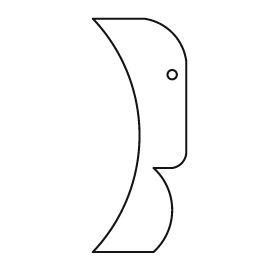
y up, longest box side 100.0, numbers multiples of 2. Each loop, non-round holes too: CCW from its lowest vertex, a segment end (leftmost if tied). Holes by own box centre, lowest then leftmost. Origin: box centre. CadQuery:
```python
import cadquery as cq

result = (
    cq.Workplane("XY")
    .moveTo(-20.0, -50.0)
    .lineTo(6.0, -50.0)
    .threePointArc((14.0, -32.0), (6.0, -14.0))
    .lineTo(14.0, -14.0)
    .threePointArc((18.0, -12.0), (20.0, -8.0))
    .lineTo(20.0, 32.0)
    .threePointArc((14.0, 44.0), (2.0, 50.0))
    .lineTo(-20.0, 50.0)
    .threePointArc((0.0, 0.0), (-20.0, -50.0))
    .close()
    .moveTo(14.0, 26.0)
    .circle(2.0)
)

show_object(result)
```